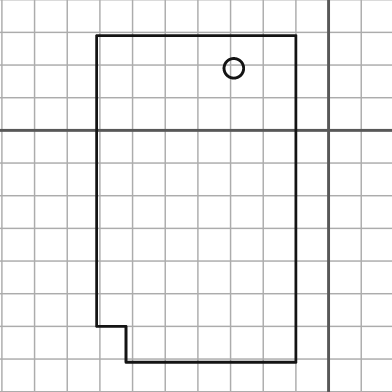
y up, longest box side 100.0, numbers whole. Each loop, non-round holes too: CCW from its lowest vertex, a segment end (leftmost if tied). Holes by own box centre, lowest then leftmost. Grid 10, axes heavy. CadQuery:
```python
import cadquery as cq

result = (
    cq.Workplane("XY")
    .moveTo(-62.0, -71.0)
    .lineTo(-10.0, -71.0)
    .lineTo(-10.0, 29.0)
    .lineTo(-71.0, 29.0)
    .lineTo(-71.0, -60.0)
    .lineTo(-62.0, -60.0)
    .close()
    .moveTo(-29.0, 19.0)
    .circle(3.0)
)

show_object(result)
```